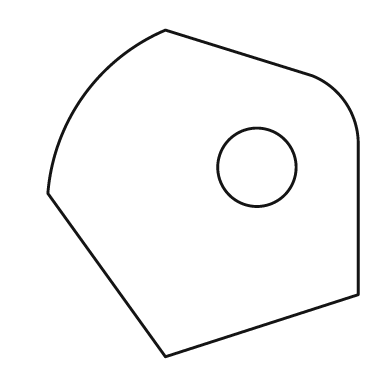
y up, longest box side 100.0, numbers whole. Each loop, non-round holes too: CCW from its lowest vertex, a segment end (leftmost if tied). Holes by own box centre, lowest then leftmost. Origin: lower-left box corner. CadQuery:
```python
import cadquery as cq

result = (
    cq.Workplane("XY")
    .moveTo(36.0, 0.0)
    .lineTo(95.0, 19.0)
    .lineTo(95.0, 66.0)
    .threePointArc((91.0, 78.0), (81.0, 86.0))
    .lineTo(36.0, 100.0)
    .threePointArc((11.0, 80.0), (0.0, 50.0))
    .close()
    .moveTo(64.0, 58.0)
    .circle(12.0)
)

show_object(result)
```